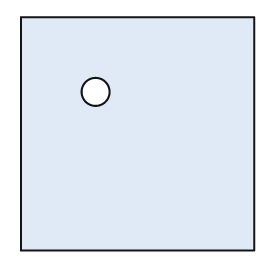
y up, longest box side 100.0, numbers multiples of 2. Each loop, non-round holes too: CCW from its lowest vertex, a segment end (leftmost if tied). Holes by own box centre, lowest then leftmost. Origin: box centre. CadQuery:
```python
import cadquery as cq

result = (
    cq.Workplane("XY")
    .moveTo(-50.0, -50.0)
    .lineTo(50.0, -50.0)
    .lineTo(50.0, 50.0)
    .lineTo(-50.0, 50.0)
    .close()
    .moveTo(-18.0, 18.0)
    .circle(6.0)
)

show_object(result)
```